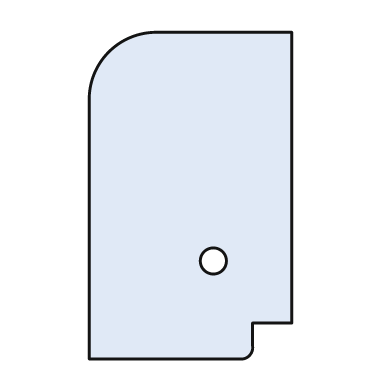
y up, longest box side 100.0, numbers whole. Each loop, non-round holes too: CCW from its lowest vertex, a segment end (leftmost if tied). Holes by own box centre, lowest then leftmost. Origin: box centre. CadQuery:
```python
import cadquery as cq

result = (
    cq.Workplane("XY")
    .moveTo(-31.0, -50.0)
    .lineTo(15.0, -50.0)
    .threePointArc((18.0, -49.0), (19.0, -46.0))
    .lineTo(19.0, -39.0)
    .lineTo(31.0, -39.0)
    .lineTo(31.0, 50.0)
    .lineTo(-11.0, 50.0)
    .threePointArc((-25.0, 44.0), (-31.0, 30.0))
    .close()
    .moveTo(7.0, -20.0)
    .circle(4.0)
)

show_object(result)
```